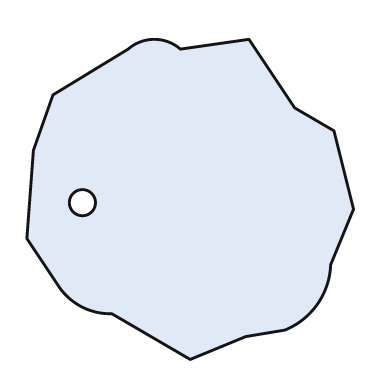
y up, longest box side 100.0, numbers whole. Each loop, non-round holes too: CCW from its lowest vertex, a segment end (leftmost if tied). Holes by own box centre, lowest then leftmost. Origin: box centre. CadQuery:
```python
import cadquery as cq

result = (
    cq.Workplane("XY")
    .moveTo(0.0, -49.0)
    .lineTo(17.0, -42.0)
    .lineTo(29.0, -40.0)
    .threePointArc((39.0, -32.0), (43.0, -20.0))
    .lineTo(50.0, -3.0)
    .lineTo(44.0, 21.0)
    .lineTo(32.0, 28.0)
    .lineTo(18.0, 49.0)
    .lineTo(-3.0, 46.0)
    .threePointArc((-11.0, 49.0), (-19.0, 46.0))
    .lineTo(-42.0, 32.0)
    .lineTo(-48.0, 15.0)
    .lineTo(-50.0, -12.0)
    .lineTo(-40.0, -27.0)
    .threePointArc((-33.0, -33.0), (-24.0, -35.0))
    .close()
    .moveTo(-33.0, -1.0)
    .circle(4.0)
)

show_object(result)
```